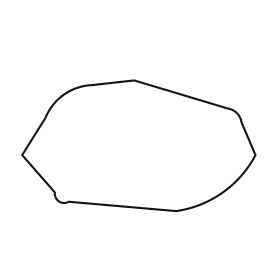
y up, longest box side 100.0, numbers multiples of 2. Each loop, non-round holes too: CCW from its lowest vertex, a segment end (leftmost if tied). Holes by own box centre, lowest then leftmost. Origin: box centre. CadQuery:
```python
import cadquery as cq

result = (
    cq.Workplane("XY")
    .moveTo(16.0, -28.0)
    .threePointArc((36.0, -20.0), (50.0, -4.0))
    .lineTo(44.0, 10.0)
    .threePointArc((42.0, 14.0), (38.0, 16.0))
    .lineTo(-2.0, 28.0)
    .lineTo(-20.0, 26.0)
    .threePointArc((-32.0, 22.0), (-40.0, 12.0))
    .lineTo(-50.0, -4.0)
    .lineTo(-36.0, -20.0)
    .threePointArc((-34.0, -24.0), (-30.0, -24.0))
    .close()
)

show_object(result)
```